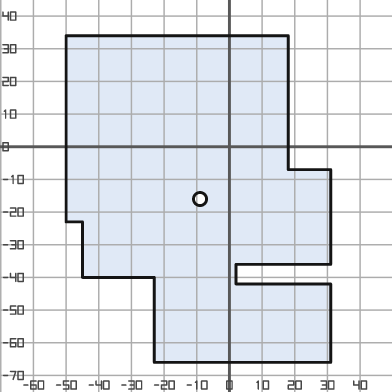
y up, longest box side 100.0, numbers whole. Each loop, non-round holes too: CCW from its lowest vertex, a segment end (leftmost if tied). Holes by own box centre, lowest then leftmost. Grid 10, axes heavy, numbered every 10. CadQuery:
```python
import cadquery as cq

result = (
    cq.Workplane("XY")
    .moveTo(-23.0, -66.0)
    .lineTo(31.0, -66.0)
    .lineTo(31.0, -42.0)
    .lineTo(2.0, -42.0)
    .lineTo(2.0, -36.0)
    .lineTo(31.0, -36.0)
    .lineTo(31.0, -7.0)
    .lineTo(18.0, -7.0)
    .lineTo(18.0, 34.0)
    .lineTo(-50.0, 34.0)
    .lineTo(-50.0, -23.0)
    .lineTo(-45.0, -23.0)
    .lineTo(-45.0, -40.0)
    .lineTo(-23.0, -40.0)
    .close()
    .moveTo(-9.0, -16.0)
    .circle(2.0)
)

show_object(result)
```